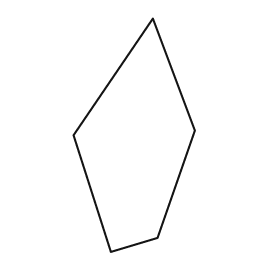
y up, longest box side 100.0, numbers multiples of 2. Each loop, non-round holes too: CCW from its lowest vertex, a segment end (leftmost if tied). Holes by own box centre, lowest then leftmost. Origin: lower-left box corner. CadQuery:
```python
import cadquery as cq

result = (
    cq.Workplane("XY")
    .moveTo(16.0, 0.0)
    .lineTo(36.0, 6.0)
    .lineTo(52.0, 52.0)
    .lineTo(34.0, 100.0)
    .lineTo(0.0, 50.0)
    .close()
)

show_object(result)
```